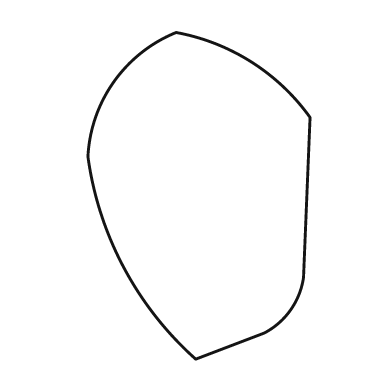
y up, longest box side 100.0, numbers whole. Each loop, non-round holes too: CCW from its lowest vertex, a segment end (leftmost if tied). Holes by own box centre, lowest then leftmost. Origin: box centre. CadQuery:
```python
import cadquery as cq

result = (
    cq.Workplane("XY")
    .moveTo(-1.0, -50.0)
    .lineTo(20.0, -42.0)
    .threePointArc((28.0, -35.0), (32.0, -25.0))
    .lineTo(34.0, 24.0)
    .threePointArc((16.0, 41.0), (-7.0, 50.0))
    .threePointArc((-26.0, 35.0), (-34.0, 12.0))
    .threePointArc((-23.0, -22.0), (-1.0, -50.0))
    .close()
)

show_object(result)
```